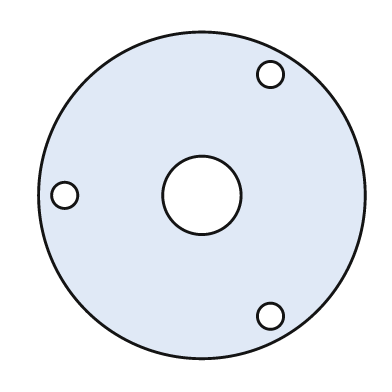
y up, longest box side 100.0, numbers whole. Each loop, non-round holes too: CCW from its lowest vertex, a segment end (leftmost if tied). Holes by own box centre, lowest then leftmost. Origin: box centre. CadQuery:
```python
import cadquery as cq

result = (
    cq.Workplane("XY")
    .moveTo(0.0, 0.0)
    .circle(50.0)
    .moveTo(21.0, -37.0)
    .circle(4.0)
    .moveTo(-42.0, 0.0)
    .circle(4.0)
    .moveTo(0.0, 0.0)
    .circle(12.0)
    .moveTo(21.0, 37.0)
    .circle(4.0)
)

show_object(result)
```